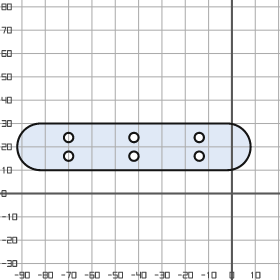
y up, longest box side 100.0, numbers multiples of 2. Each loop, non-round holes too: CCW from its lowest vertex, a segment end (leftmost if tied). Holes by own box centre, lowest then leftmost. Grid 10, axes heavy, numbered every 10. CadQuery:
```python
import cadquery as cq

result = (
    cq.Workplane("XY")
    .moveTo(-82.0, 10.0)
    .lineTo(-2.0, 10.0)
    .threePointArc((8.0, 20.0), (-2.0, 30.0))
    .lineTo(-82.0, 30.0)
    .threePointArc((-92.0, 20.0), (-82.0, 10.0))
    .close()
    .moveTo(-70.0, 16.0)
    .circle(2.0)
    .moveTo(-42.0, 16.0)
    .circle(2.0)
    .moveTo(-14.0, 16.0)
    .circle(2.0)
    .moveTo(-70.0, 24.0)
    .circle(2.0)
    .moveTo(-42.0, 24.0)
    .circle(2.0)
    .moveTo(-14.0, 24.0)
    .circle(2.0)
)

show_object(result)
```